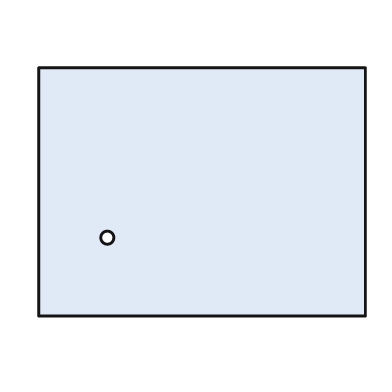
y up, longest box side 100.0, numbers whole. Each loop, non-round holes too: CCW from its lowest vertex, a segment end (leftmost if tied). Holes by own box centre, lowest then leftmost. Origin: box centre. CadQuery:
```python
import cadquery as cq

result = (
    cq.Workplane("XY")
    .moveTo(-50.0, -38.0)
    .lineTo(50.0, -38.0)
    .lineTo(50.0, 38.0)
    .lineTo(-50.0, 38.0)
    .close()
    .moveTo(-29.0, -14.0)
    .circle(2.0)
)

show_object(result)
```